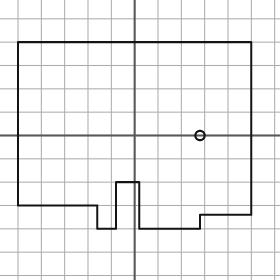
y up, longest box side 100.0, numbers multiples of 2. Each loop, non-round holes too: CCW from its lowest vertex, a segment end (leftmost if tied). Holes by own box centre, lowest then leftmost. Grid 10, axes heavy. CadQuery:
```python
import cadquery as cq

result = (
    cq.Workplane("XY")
    .moveTo(-16.0, -40.0)
    .lineTo(-8.0, -40.0)
    .lineTo(-8.0, -20.0)
    .lineTo(2.0, -20.0)
    .lineTo(2.0, -40.0)
    .lineTo(28.0, -40.0)
    .lineTo(28.0, -34.0)
    .lineTo(50.0, -34.0)
    .lineTo(50.0, 40.0)
    .lineTo(-50.0, 40.0)
    .lineTo(-50.0, -30.0)
    .lineTo(-16.0, -30.0)
    .close()
    .moveTo(28.0, 0.0)
    .circle(2.0)
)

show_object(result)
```